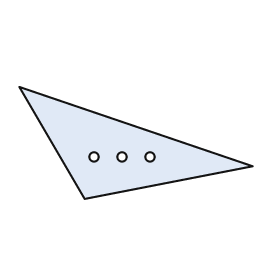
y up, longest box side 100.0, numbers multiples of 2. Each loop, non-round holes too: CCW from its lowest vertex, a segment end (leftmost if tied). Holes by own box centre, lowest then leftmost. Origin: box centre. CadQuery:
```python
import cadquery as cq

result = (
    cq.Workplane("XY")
    .moveTo(-22.0, -24.0)
    .lineTo(50.0, -10.0)
    .lineTo(-50.0, 24.0)
    .close()
    .moveTo(-18.0, -6.0)
    .circle(2.0)
    .moveTo(-6.0, -6.0)
    .circle(2.0)
    .moveTo(6.0, -6.0)
    .circle(2.0)
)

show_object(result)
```